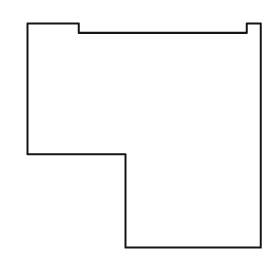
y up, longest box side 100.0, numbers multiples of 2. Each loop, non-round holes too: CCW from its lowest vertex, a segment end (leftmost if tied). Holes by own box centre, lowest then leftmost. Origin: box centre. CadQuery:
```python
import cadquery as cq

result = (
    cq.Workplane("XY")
    .moveTo(-8.0, -48.0)
    .lineTo(50.0, -48.0)
    .lineTo(50.0, 48.0)
    .lineTo(44.0, 48.0)
    .lineTo(44.0, 44.0)
    .lineTo(-28.0, 44.0)
    .lineTo(-28.0, 48.0)
    .lineTo(-50.0, 48.0)
    .lineTo(-50.0, -8.0)
    .lineTo(-8.0, -8.0)
    .close()
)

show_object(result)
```